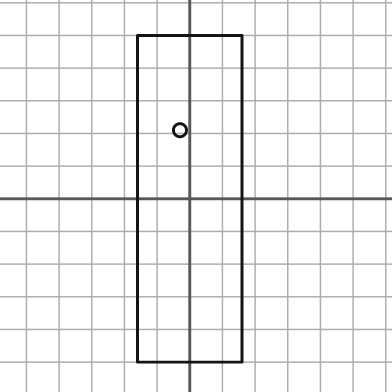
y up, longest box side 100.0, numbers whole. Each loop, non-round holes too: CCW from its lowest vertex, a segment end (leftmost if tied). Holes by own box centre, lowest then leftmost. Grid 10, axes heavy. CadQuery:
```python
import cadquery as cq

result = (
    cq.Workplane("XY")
    .moveTo(-16.0, -50.0)
    .lineTo(16.0, -50.0)
    .lineTo(16.0, 50.0)
    .lineTo(-16.0, 50.0)
    .close()
    .moveTo(-3.0, 21.0)
    .circle(2.0)
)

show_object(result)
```